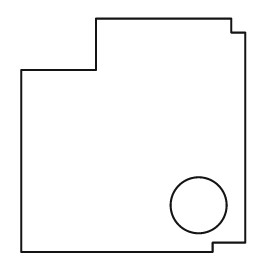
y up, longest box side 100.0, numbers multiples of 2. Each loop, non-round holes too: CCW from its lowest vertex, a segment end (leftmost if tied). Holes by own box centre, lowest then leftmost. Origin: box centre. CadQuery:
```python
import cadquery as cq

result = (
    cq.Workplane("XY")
    .moveTo(-48.0, -50.0)
    .lineTo(34.0, -50.0)
    .lineTo(34.0, -46.0)
    .lineTo(48.0, -46.0)
    .lineTo(48.0, 44.0)
    .lineTo(42.0, 44.0)
    .lineTo(42.0, 50.0)
    .lineTo(-16.0, 50.0)
    .lineTo(-16.0, 28.0)
    .lineTo(-48.0, 28.0)
    .close()
    .moveTo(28.0, -30.0)
    .circle(12.0)
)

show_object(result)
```